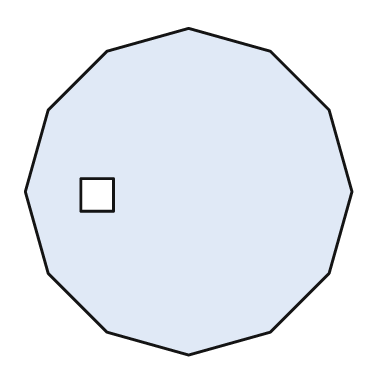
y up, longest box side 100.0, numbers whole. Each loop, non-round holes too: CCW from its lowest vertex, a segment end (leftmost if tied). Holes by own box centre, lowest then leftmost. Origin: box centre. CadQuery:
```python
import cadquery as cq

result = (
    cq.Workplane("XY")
    .moveTo(0.0, -50.0)
    .lineTo(25.0, -43.0)
    .lineTo(43.0, -25.0)
    .lineTo(50.0, 0.0)
    .lineTo(43.0, 25.0)
    .lineTo(25.0, 43.0)
    .lineTo(0.0, 50.0)
    .lineTo(-25.0, 43.0)
    .lineTo(-43.0, 25.0)
    .lineTo(-50.0, 0.0)
    .lineTo(-43.0, -25.0)
    .lineTo(-25.0, -43.0)
    .close()
    .moveTo(-33.0, -6.0)
    .lineTo(-23.0, -6.0)
    .lineTo(-23.0, 4.0)
    .lineTo(-33.0, 4.0)
    .close()
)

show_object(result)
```